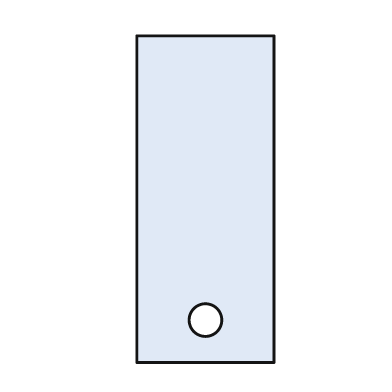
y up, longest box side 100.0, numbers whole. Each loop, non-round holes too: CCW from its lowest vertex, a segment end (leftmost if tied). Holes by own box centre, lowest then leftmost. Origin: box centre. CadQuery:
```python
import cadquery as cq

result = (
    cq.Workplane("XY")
    .moveTo(-21.0, -50.0)
    .lineTo(21.0, -50.0)
    .lineTo(21.0, 50.0)
    .lineTo(-21.0, 50.0)
    .close()
    .moveTo(0.0, -37.0)
    .circle(5.0)
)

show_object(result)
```